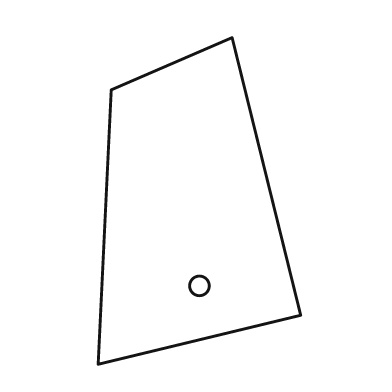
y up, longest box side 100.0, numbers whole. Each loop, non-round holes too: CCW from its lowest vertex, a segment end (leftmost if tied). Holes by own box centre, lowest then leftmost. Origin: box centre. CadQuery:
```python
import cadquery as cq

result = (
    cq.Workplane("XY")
    .moveTo(-31.0, -50.0)
    .lineTo(31.0, -35.0)
    .lineTo(10.0, 50.0)
    .lineTo(-27.0, 34.0)
    .close()
    .moveTo(0.0, -26.0)
    .circle(3.0)
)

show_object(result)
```